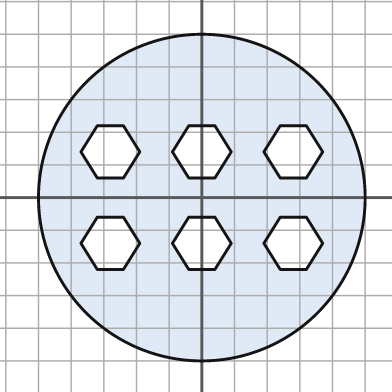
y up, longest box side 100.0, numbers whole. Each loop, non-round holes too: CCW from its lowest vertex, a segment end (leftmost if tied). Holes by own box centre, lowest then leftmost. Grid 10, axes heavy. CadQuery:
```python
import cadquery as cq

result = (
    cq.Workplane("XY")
    .moveTo(0.0, 0.0)
    .circle(50.0)
    .moveTo(-32.0, -22.0)
    .lineTo(-24.0, -22.0)
    .lineTo(-19.0, -14.0)
    .lineTo(-24.0, -6.0)
    .lineTo(-32.0, -6.0)
    .lineTo(-37.0, -14.0)
    .close()
    .moveTo(-4.0, -22.0)
    .lineTo(4.0, -22.0)
    .lineTo(9.0, -14.0)
    .lineTo(4.0, -6.0)
    .lineTo(-4.0, -6.0)
    .lineTo(-9.0, -14.0)
    .close()
    .moveTo(24.0, -22.0)
    .lineTo(32.0, -22.0)
    .lineTo(37.0, -14.0)
    .lineTo(32.0, -6.0)
    .lineTo(24.0, -6.0)
    .lineTo(19.0, -14.0)
    .close()
    .moveTo(-32.0, 6.0)
    .lineTo(-24.0, 6.0)
    .lineTo(-19.0, 14.0)
    .lineTo(-24.0, 22.0)
    .lineTo(-32.0, 22.0)
    .lineTo(-37.0, 14.0)
    .close()
    .moveTo(-4.0, 6.0)
    .lineTo(4.0, 6.0)
    .lineTo(9.0, 14.0)
    .lineTo(4.0, 22.0)
    .lineTo(-4.0, 22.0)
    .lineTo(-9.0, 14.0)
    .close()
    .moveTo(24.0, 6.0)
    .lineTo(32.0, 6.0)
    .lineTo(37.0, 14.0)
    .lineTo(32.0, 22.0)
    .lineTo(24.0, 22.0)
    .lineTo(19.0, 14.0)
    .close()
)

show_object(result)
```